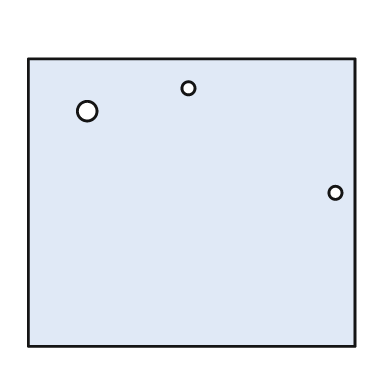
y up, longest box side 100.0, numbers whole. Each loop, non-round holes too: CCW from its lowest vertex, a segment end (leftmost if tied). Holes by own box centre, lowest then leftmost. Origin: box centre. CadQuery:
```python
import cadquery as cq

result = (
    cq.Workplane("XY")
    .moveTo(-50.0, -44.0)
    .lineTo(50.0, -44.0)
    .lineTo(50.0, 44.0)
    .lineTo(-50.0, 44.0)
    .close()
    .moveTo(44.0, 3.0)
    .circle(2.0)
    .moveTo(-32.0, 28.0)
    .circle(3.0)
    .moveTo(-1.0, 35.0)
    .circle(2.0)
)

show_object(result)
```